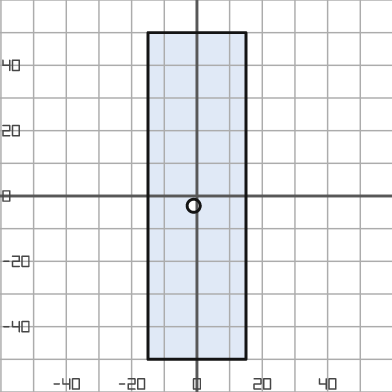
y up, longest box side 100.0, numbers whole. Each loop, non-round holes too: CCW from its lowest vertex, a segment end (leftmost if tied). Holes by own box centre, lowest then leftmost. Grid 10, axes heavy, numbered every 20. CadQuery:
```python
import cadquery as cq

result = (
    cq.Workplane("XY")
    .moveTo(-15.0, -50.0)
    .lineTo(15.0, -50.0)
    .lineTo(15.0, 50.0)
    .lineTo(-15.0, 50.0)
    .close()
    .moveTo(-1.0, -3.0)
    .circle(2.0)
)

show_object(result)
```